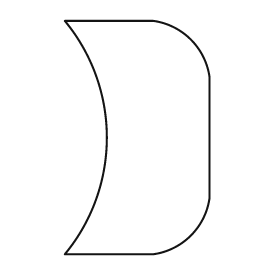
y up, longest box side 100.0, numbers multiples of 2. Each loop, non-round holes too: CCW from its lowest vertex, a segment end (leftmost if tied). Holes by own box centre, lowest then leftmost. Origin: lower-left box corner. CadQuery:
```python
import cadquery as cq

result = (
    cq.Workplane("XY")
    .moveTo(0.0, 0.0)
    .lineTo(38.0, 0.0)
    .threePointArc((54.0, 8.0), (62.0, 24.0))
    .lineTo(62.0, 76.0)
    .threePointArc((54.0, 92.0), (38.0, 100.0))
    .lineTo(0.0, 100.0)
    .threePointArc((18.0, 50.0), (0.0, 0.0))
    .close()
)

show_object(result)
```